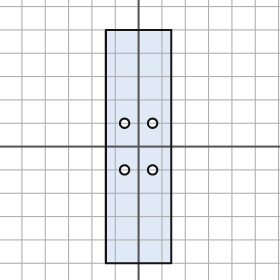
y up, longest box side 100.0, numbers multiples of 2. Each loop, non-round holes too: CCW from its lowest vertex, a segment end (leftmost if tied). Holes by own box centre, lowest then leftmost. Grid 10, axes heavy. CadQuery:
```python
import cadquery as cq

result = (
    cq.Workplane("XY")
    .moveTo(-14.0, -50.0)
    .lineTo(14.0, -50.0)
    .lineTo(14.0, 50.0)
    .lineTo(-14.0, 50.0)
    .close()
    .moveTo(-6.0, -10.0)
    .circle(2.0)
    .moveTo(6.0, -10.0)
    .circle(2.0)
    .moveTo(-6.0, 10.0)
    .circle(2.0)
    .moveTo(6.0, 10.0)
    .circle(2.0)
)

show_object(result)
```